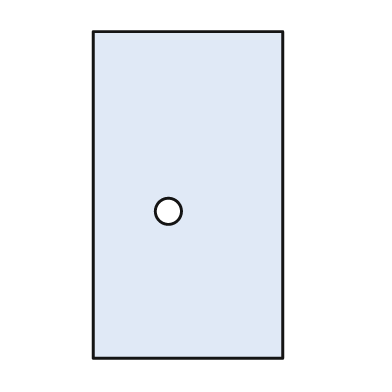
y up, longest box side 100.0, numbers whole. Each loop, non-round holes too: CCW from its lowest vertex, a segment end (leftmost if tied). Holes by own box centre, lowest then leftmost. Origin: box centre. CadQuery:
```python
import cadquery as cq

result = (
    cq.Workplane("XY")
    .moveTo(-29.0, -50.0)
    .lineTo(29.0, -50.0)
    .lineTo(29.0, 50.0)
    .lineTo(-29.0, 50.0)
    .close()
    .moveTo(-6.0, -5.0)
    .circle(4.0)
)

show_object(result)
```